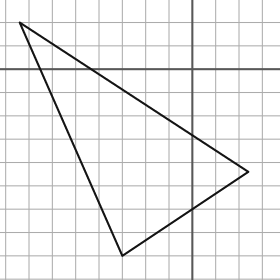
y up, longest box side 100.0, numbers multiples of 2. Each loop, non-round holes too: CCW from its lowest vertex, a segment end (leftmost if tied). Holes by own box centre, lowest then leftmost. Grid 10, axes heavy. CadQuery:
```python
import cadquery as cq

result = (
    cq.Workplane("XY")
    .moveTo(-30.0, -80.0)
    .lineTo(24.0, -44.0)
    .lineTo(-74.0, 20.0)
    .close()
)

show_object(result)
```